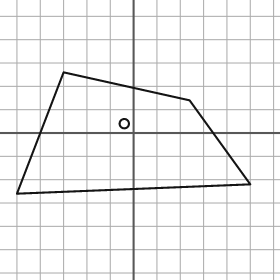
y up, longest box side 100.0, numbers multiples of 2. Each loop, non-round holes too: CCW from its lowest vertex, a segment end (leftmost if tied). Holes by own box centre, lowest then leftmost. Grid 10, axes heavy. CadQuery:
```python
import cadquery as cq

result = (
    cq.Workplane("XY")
    .moveTo(-50.0, -26.0)
    .lineTo(50.0, -22.0)
    .lineTo(24.0, 14.0)
    .lineTo(-30.0, 26.0)
    .close()
    .moveTo(-4.0, 4.0)
    .circle(2.0)
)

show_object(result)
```